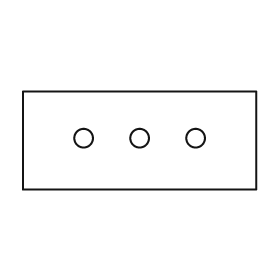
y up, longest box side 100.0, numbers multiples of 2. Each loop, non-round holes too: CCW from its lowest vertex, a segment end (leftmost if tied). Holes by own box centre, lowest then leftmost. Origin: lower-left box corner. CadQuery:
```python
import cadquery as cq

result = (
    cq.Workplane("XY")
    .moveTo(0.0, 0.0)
    .lineTo(100.0, 0.0)
    .lineTo(100.0, 42.0)
    .lineTo(0.0, 42.0)
    .close()
    .moveTo(26.0, 22.0)
    .circle(4.0)
    .moveTo(50.0, 22.0)
    .circle(4.0)
    .moveTo(74.0, 22.0)
    .circle(4.0)
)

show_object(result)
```